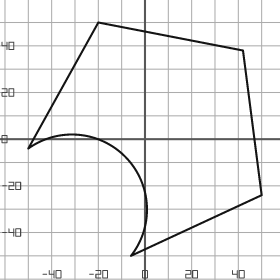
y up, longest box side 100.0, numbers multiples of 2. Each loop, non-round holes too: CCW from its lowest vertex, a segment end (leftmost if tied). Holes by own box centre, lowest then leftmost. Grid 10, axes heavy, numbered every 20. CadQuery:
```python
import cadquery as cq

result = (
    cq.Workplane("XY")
    .moveTo(-6.0, -50.0)
    .lineTo(50.0, -24.0)
    .lineTo(42.0, 38.0)
    .lineTo(-20.0, 50.0)
    .lineTo(-50.0, -4.0)
    .threePointArc((-8.0, -8.0), (-6.0, -50.0))
    .close()
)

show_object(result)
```